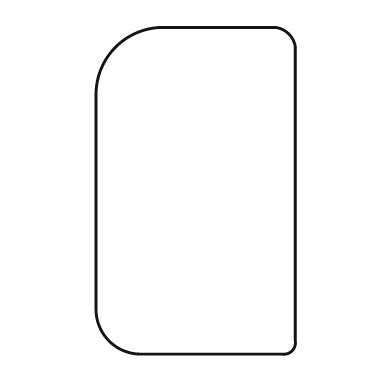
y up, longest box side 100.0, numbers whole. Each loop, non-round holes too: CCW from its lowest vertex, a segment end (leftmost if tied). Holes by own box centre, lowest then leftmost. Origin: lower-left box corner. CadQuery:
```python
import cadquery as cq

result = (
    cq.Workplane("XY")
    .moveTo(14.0, 0.0)
    .lineTo(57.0, 0.0)
    .threePointArc((60.0, 1.0), (61.0, 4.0))
    .lineTo(61.0, 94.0)
    .threePointArc((59.0, 98.0), (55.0, 100.0))
    .lineTo(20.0, 100.0)
    .threePointArc((6.0, 94.0), (0.0, 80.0))
    .lineTo(0.0, 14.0)
    .threePointArc((4.0, 4.0), (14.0, 0.0))
    .close()
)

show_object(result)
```